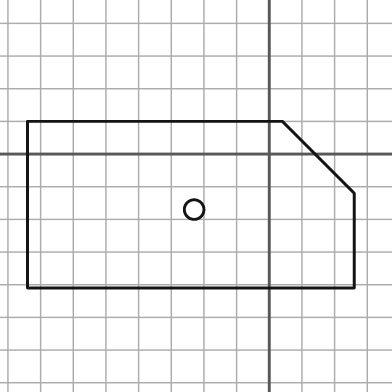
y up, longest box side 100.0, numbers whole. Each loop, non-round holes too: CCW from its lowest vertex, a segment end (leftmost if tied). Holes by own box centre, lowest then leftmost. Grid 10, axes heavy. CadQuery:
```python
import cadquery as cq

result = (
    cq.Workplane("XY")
    .moveTo(-74.0, -41.0)
    .lineTo(26.0, -41.0)
    .lineTo(26.0, -12.0)
    .lineTo(4.0, 10.0)
    .lineTo(-74.0, 10.0)
    .close()
    .moveTo(-23.0, -17.0)
    .circle(3.0)
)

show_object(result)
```